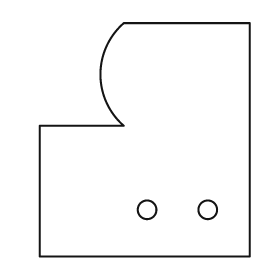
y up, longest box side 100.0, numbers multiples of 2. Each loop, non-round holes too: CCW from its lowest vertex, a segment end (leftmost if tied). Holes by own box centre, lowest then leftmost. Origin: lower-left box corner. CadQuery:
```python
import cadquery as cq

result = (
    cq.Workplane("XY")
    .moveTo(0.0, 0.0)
    .lineTo(90.0, 0.0)
    .lineTo(90.0, 100.0)
    .lineTo(36.0, 100.0)
    .threePointArc((26.0, 78.0), (36.0, 56.0))
    .lineTo(0.0, 56.0)
    .close()
    .moveTo(46.0, 20.0)
    .circle(4.0)
    .moveTo(72.0, 20.0)
    .circle(4.0)
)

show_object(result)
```